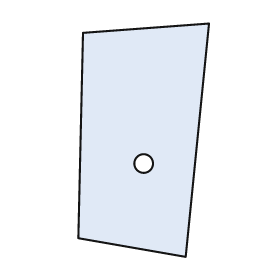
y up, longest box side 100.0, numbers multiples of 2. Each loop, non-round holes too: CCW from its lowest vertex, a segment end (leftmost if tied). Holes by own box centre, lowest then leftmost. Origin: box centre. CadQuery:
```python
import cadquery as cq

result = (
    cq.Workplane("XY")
    .moveTo(18.0, -50.0)
    .lineTo(28.0, 50.0)
    .lineTo(-26.0, 46.0)
    .lineTo(-28.0, -42.0)
    .close()
    .moveTo(0.0, -10.0)
    .circle(4.0)
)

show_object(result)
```